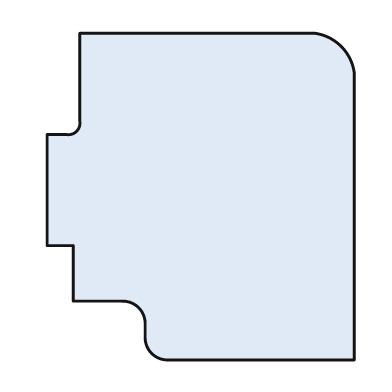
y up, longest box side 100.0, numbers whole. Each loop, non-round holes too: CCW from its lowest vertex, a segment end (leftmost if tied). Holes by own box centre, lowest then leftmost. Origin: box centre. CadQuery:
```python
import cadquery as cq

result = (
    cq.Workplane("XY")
    .moveTo(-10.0, -50.0)
    .lineTo(47.0, -50.0)
    .lineTo(47.0, 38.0)
    .threePointArc((43.0, 46.0), (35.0, 50.0))
    .lineTo(-37.0, 50.0)
    .lineTo(-37.0, 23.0)
    .threePointArc((-38.0, 20.0), (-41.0, 19.0))
    .lineTo(-47.0, 19.0)
    .lineTo(-47.0, -15.0)
    .lineTo(-39.0, -15.0)
    .lineTo(-39.0, -32.0)
    .lineTo(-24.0, -32.0)
    .threePointArc((-19.0, -34.0), (-17.0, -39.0))
    .lineTo(-17.0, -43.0)
    .threePointArc((-15.0, -48.0), (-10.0, -50.0))
    .close()
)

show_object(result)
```